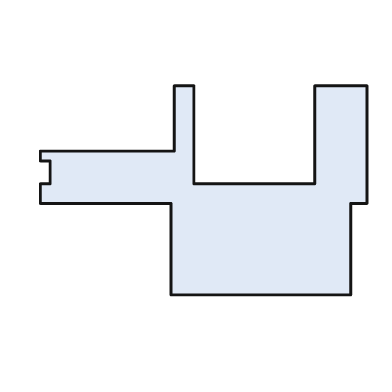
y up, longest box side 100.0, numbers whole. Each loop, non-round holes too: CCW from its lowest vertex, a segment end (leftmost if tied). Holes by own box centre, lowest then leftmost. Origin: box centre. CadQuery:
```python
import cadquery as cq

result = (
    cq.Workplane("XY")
    .moveTo(-10.0, -32.0)
    .lineTo(45.0, -32.0)
    .lineTo(45.0, -4.0)
    .lineTo(50.0, -4.0)
    .lineTo(50.0, 32.0)
    .lineTo(34.0, 32.0)
    .lineTo(34.0, 2.0)
    .lineTo(-3.0, 2.0)
    .lineTo(-3.0, 32.0)
    .lineTo(-9.0, 32.0)
    .lineTo(-9.0, 12.0)
    .lineTo(-50.0, 12.0)
    .lineTo(-50.0, 9.0)
    .lineTo(-47.0, 9.0)
    .lineTo(-47.0, 2.0)
    .lineTo(-50.0, 2.0)
    .lineTo(-50.0, -4.0)
    .lineTo(-10.0, -4.0)
    .close()
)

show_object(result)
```